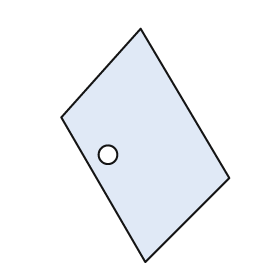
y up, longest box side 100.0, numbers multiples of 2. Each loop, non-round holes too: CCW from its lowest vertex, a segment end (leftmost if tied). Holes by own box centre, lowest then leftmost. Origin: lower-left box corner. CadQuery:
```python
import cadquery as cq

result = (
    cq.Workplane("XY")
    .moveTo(36.0, 0.0)
    .lineTo(72.0, 36.0)
    .lineTo(34.0, 100.0)
    .lineTo(0.0, 62.0)
    .close()
    .moveTo(20.0, 46.0)
    .circle(4.0)
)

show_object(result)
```